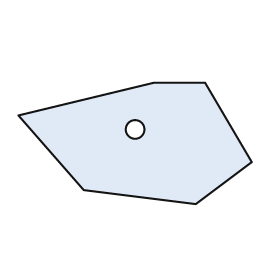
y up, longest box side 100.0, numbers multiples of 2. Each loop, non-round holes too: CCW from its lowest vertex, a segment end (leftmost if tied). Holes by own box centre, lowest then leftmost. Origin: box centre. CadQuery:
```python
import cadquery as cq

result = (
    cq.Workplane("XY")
    .moveTo(26.0, -26.0)
    .lineTo(50.0, -8.0)
    .lineTo(30.0, 26.0)
    .lineTo(8.0, 26.0)
    .lineTo(-50.0, 12.0)
    .lineTo(-22.0, -20.0)
    .close()
    .moveTo(0.0, 6.0)
    .circle(4.0)
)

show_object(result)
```